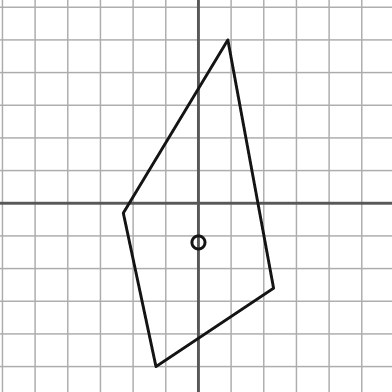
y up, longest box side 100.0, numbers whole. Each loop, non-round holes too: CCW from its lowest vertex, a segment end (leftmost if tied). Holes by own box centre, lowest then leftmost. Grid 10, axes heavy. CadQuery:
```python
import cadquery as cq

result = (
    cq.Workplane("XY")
    .moveTo(-13.0, -50.0)
    .lineTo(23.0, -26.0)
    .lineTo(9.0, 50.0)
    .lineTo(-23.0, -3.0)
    .close()
    .moveTo(0.0, -12.0)
    .circle(2.0)
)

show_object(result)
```